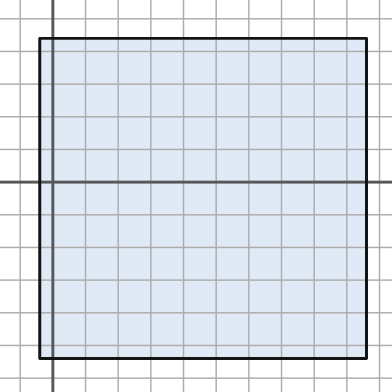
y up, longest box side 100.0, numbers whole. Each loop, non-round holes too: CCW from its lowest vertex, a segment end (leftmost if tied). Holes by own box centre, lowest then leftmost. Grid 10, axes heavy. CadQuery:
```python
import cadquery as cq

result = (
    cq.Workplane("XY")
    .moveTo(-4.0, -54.0)
    .lineTo(96.0, -54.0)
    .lineTo(96.0, 44.0)
    .lineTo(-4.0, 44.0)
    .close()
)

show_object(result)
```